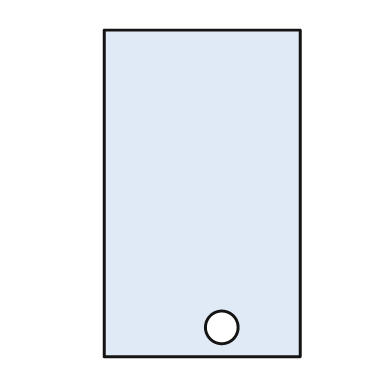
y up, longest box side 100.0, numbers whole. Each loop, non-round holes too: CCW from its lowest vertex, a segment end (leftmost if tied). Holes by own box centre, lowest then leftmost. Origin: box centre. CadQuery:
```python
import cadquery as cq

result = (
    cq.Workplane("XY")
    .moveTo(-30.0, -50.0)
    .lineTo(30.0, -50.0)
    .lineTo(30.0, 50.0)
    .lineTo(-30.0, 50.0)
    .close()
    .moveTo(6.0, -41.0)
    .circle(5.0)
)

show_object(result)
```